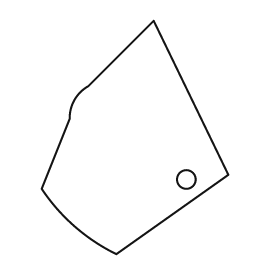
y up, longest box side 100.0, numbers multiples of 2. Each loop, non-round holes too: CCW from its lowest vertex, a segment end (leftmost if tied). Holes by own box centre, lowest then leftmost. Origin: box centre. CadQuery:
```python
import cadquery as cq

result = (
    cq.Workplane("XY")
    .moveTo(-8.0, -50.0)
    .lineTo(40.0, -16.0)
    .lineTo(8.0, 50.0)
    .lineTo(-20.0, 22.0)
    .threePointArc((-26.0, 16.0), (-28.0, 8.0))
    .lineTo(-40.0, -22.0)
    .threePointArc((-26.0, -38.0), (-8.0, -50.0))
    .close()
    .moveTo(22.0, -18.0)
    .circle(4.0)
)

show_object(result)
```